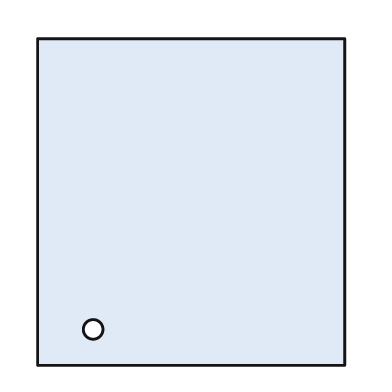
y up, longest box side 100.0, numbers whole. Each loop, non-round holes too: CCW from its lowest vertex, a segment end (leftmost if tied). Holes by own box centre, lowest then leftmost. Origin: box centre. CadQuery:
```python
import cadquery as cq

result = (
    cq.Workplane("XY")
    .moveTo(-47.0, -50.0)
    .lineTo(47.0, -50.0)
    .lineTo(47.0, 50.0)
    .lineTo(-47.0, 50.0)
    .close()
    .moveTo(-30.0, -39.0)
    .circle(3.0)
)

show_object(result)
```